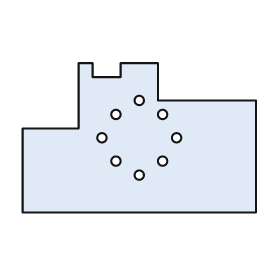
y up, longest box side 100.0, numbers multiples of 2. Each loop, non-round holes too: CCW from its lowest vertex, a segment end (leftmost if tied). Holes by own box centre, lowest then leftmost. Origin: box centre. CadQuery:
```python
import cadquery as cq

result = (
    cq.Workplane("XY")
    .moveTo(-50.0, -32.0)
    .lineTo(50.0, -32.0)
    .lineTo(50.0, 16.0)
    .lineTo(8.0, 16.0)
    .lineTo(8.0, 32.0)
    .lineTo(-8.0, 32.0)
    .lineTo(-8.0, 26.0)
    .lineTo(-20.0, 26.0)
    .lineTo(-20.0, 32.0)
    .lineTo(-26.0, 32.0)
    .lineTo(-26.0, 4.0)
    .lineTo(-50.0, 4.0)
    .close()
    .moveTo(0.0, -16.0)
    .circle(2.0)
    .moveTo(-10.0, -10.0)
    .circle(2.0)
    .moveTo(10.0, -10.0)
    .circle(2.0)
    .moveTo(-16.0, 0.0)
    .circle(2.0)
    .moveTo(16.0, 0.0)
    .circle(2.0)
    .moveTo(-10.0, 10.0)
    .circle(2.0)
    .moveTo(10.0, 10.0)
    .circle(2.0)
    .moveTo(0.0, 16.0)
    .circle(2.0)
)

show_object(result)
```